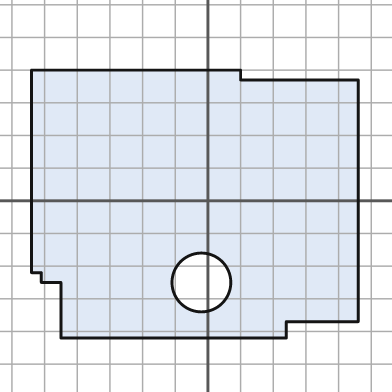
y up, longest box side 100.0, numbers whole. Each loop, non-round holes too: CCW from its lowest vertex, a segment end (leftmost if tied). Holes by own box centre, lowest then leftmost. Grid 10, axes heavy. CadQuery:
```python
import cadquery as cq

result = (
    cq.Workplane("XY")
    .moveTo(-45.0, -42.0)
    .lineTo(24.0, -42.0)
    .lineTo(24.0, -37.0)
    .lineTo(46.0, -37.0)
    .lineTo(46.0, 37.0)
    .lineTo(10.0, 37.0)
    .lineTo(10.0, 40.0)
    .lineTo(-54.0, 40.0)
    .lineTo(-54.0, -22.0)
    .lineTo(-51.0, -22.0)
    .lineTo(-51.0, -25.0)
    .lineTo(-45.0, -25.0)
    .close()
    .moveTo(-2.0, -25.0)
    .circle(9.0)
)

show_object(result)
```